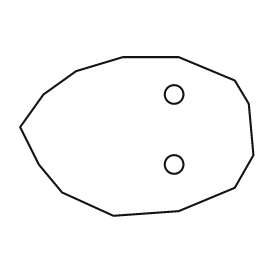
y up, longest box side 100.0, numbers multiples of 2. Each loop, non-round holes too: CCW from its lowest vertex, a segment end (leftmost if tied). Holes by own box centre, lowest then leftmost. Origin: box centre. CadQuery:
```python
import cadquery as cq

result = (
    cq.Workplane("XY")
    .moveTo(-10.0, -34.0)
    .lineTo(18.0, -32.0)
    .lineTo(42.0, -22.0)
    .lineTo(50.0, -8.0)
    .lineTo(48.0, 14.0)
    .lineTo(42.0, 24.0)
    .lineTo(18.0, 34.0)
    .lineTo(-6.0, 34.0)
    .lineTo(-26.0, 28.0)
    .lineTo(-40.0, 18.0)
    .lineTo(-50.0, 4.0)
    .lineTo(-42.0, -12.0)
    .lineTo(-32.0, -24.0)
    .close()
    .moveTo(16.0, -12.0)
    .circle(4.0)
    .moveTo(16.0, 18.0)
    .circle(4.0)
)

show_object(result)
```